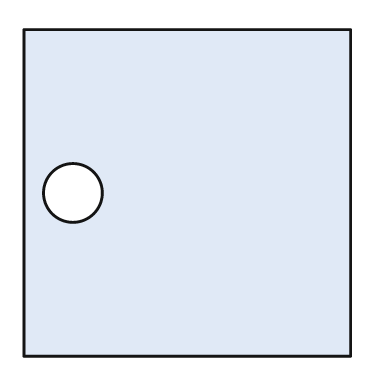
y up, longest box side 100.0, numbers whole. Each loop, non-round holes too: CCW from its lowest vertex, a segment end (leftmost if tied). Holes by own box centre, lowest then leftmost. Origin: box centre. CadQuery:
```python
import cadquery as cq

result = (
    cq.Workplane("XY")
    .moveTo(-50.0, -50.0)
    .lineTo(50.0, -50.0)
    .lineTo(50.0, 50.0)
    .lineTo(-50.0, 50.0)
    .close()
    .moveTo(-35.0, 0.0)
    .circle(9.0)
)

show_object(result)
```